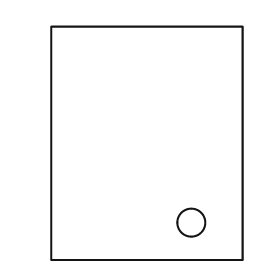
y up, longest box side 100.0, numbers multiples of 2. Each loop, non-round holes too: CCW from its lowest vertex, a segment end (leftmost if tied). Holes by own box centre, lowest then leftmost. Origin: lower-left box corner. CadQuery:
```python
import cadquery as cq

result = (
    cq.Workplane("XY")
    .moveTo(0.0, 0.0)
    .lineTo(82.0, 0.0)
    .lineTo(82.0, 100.0)
    .lineTo(0.0, 100.0)
    .close()
    .moveTo(60.0, 16.0)
    .circle(6.0)
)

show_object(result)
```